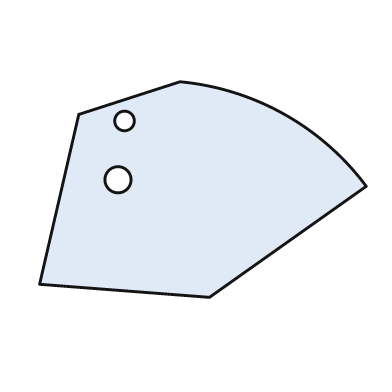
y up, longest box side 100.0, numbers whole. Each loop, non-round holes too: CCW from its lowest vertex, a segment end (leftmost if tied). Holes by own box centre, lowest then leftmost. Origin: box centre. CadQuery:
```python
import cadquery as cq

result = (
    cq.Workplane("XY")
    .moveTo(2.0, -33.0)
    .lineTo(50.0, 1.0)
    .threePointArc((25.0, 23.0), (-7.0, 33.0))
    .lineTo(-38.0, 23.0)
    .lineTo(-50.0, -29.0)
    .close()
    .moveTo(-26.0, 3.0)
    .circle(4.0)
    .moveTo(-24.0, 21.0)
    .circle(3.0)
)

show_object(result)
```